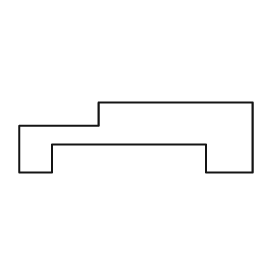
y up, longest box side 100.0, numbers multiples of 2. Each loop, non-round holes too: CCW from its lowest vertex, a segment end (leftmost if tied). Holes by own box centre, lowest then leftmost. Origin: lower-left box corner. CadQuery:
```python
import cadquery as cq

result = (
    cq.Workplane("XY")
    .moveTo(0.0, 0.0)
    .lineTo(14.0, 0.0)
    .lineTo(14.0, 12.0)
    .lineTo(80.0, 12.0)
    .lineTo(80.0, 0.0)
    .lineTo(100.0, 0.0)
    .lineTo(100.0, 30.0)
    .lineTo(34.0, 30.0)
    .lineTo(34.0, 20.0)
    .lineTo(0.0, 20.0)
    .close()
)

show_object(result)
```